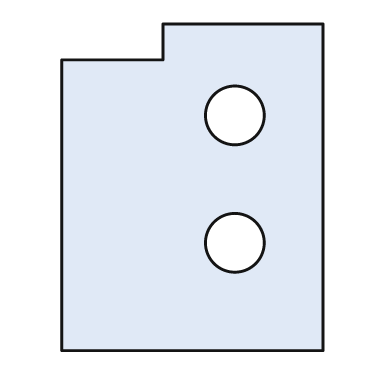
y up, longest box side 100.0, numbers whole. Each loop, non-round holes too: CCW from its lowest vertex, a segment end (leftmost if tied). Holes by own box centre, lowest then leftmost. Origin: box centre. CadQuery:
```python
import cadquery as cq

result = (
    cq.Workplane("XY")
    .moveTo(-40.0, -50.0)
    .lineTo(40.0, -50.0)
    .lineTo(40.0, 50.0)
    .lineTo(-9.0, 50.0)
    .lineTo(-9.0, 39.0)
    .lineTo(-40.0, 39.0)
    .close()
    .moveTo(13.0, -17.0)
    .circle(9.0)
    .moveTo(13.0, 22.0)
    .circle(9.0)
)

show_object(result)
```